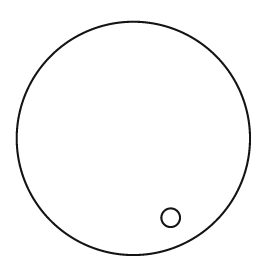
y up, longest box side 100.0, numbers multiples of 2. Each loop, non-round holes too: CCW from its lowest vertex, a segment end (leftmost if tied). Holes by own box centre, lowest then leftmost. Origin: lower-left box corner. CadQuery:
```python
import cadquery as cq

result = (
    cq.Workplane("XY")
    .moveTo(50.0, 50.0)
    .circle(50.0)
    .moveTo(66.0, 16.0)
    .circle(4.0)
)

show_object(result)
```